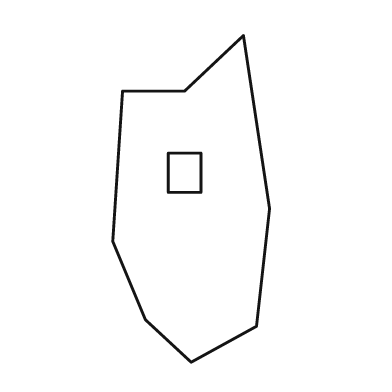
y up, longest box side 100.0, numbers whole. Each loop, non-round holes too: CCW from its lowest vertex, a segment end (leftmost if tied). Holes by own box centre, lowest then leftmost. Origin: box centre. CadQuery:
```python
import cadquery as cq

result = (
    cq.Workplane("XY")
    .moveTo(0.0, -50.0)
    .lineTo(20.0, -39.0)
    .lineTo(24.0, -3.0)
    .lineTo(16.0, 50.0)
    .lineTo(-2.0, 33.0)
    .lineTo(-21.0, 33.0)
    .lineTo(-24.0, -13.0)
    .lineTo(-14.0, -37.0)
    .close()
    .moveTo(-7.0, 2.0)
    .lineTo(3.0, 2.0)
    .lineTo(3.0, 14.0)
    .lineTo(-7.0, 14.0)
    .close()
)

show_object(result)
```